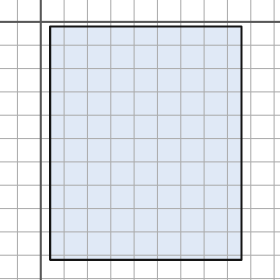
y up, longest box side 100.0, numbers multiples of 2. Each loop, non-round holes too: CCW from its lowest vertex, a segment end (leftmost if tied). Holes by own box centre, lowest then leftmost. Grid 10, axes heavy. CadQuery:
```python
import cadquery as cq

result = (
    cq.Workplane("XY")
    .moveTo(4.0, -102.0)
    .lineTo(86.0, -102.0)
    .lineTo(86.0, -2.0)
    .lineTo(4.0, -2.0)
    .close()
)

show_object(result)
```